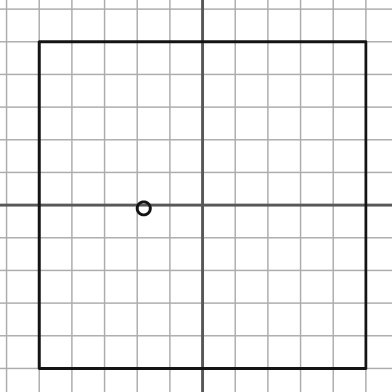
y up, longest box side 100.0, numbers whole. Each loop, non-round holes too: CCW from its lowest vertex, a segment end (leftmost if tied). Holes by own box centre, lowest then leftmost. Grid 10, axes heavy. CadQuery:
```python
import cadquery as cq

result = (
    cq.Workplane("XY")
    .moveTo(-50.0, -50.0)
    .lineTo(50.0, -50.0)
    .lineTo(50.0, 50.0)
    .lineTo(-50.0, 50.0)
    .close()
    .moveTo(-18.0, -1.0)
    .circle(2.0)
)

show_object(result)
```